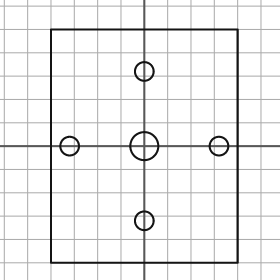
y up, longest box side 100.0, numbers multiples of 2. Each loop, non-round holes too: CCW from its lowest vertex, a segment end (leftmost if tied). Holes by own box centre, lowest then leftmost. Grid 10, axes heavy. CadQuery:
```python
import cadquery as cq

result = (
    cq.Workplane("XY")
    .moveTo(-40.0, -50.0)
    .lineTo(40.0, -50.0)
    .lineTo(40.0, 50.0)
    .lineTo(-40.0, 50.0)
    .close()
    .moveTo(0.0, -32.0)
    .circle(4.0)
    .moveTo(-32.0, 0.0)
    .circle(4.0)
    .moveTo(0.0, 0.0)
    .circle(6.0)
    .moveTo(32.0, 0.0)
    .circle(4.0)
    .moveTo(0.0, 32.0)
    .circle(4.0)
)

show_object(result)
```